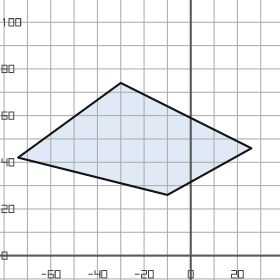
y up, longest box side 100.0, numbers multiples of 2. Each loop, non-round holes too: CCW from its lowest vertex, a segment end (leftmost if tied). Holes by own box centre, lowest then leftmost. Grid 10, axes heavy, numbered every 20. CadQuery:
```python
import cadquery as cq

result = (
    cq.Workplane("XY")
    .moveTo(-10.0, 26.0)
    .lineTo(26.0, 46.0)
    .lineTo(-30.0, 74.0)
    .lineTo(-74.0, 42.0)
    .close()
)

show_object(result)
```